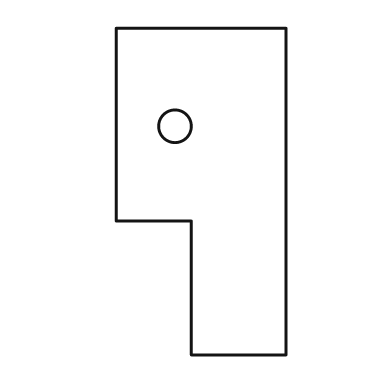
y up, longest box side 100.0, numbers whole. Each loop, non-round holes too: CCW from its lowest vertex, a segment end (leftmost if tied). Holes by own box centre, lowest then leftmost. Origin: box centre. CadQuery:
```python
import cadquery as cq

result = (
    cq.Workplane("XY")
    .moveTo(-3.0, -50.0)
    .lineTo(26.0, -50.0)
    .lineTo(26.0, 50.0)
    .lineTo(-26.0, 50.0)
    .lineTo(-26.0, -9.0)
    .lineTo(-3.0, -9.0)
    .close()
    .moveTo(-8.0, 20.0)
    .circle(5.0)
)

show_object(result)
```